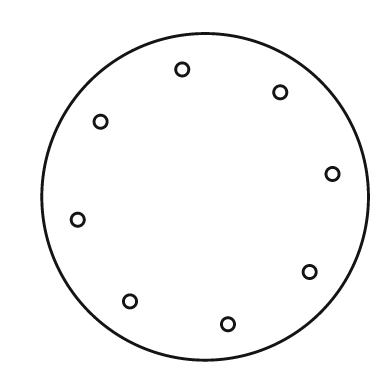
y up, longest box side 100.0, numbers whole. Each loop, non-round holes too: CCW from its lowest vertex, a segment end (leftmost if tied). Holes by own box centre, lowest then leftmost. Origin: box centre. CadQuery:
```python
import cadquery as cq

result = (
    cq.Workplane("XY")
    .moveTo(0.0, 0.0)
    .circle(50.0)
    .moveTo(7.0, -39.0)
    .circle(2.0)
    .moveTo(-23.0, -32.0)
    .circle(2.0)
    .moveTo(32.0, -23.0)
    .circle(2.0)
    .moveTo(-39.0, -7.0)
    .circle(2.0)
    .moveTo(39.0, 7.0)
    .circle(2.0)
    .moveTo(-32.0, 23.0)
    .circle(2.0)
    .moveTo(23.0, 32.0)
    .circle(2.0)
    .moveTo(-7.0, 39.0)
    .circle(2.0)
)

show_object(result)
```